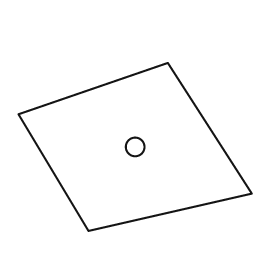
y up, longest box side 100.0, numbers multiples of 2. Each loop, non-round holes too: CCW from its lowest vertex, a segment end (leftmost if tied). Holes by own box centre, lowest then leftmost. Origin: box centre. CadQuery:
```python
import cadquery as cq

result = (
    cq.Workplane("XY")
    .moveTo(-20.0, -36.0)
    .lineTo(50.0, -20.0)
    .lineTo(14.0, 36.0)
    .lineTo(-50.0, 14.0)
    .close()
    .moveTo(0.0, 0.0)
    .circle(4.0)
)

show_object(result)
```